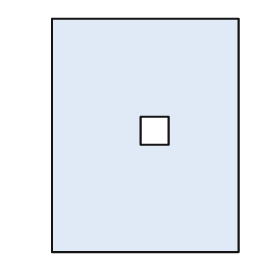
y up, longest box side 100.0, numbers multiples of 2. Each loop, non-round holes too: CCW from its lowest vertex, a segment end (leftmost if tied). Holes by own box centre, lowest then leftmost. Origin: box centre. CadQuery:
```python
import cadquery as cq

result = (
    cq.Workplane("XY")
    .moveTo(-40.0, -50.0)
    .lineTo(40.0, -50.0)
    .lineTo(40.0, 50.0)
    .lineTo(-40.0, 50.0)
    .close()
    .moveTo(-2.0, -4.0)
    .lineTo(10.0, -4.0)
    .lineTo(10.0, 8.0)
    .lineTo(-2.0, 8.0)
    .close()
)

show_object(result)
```